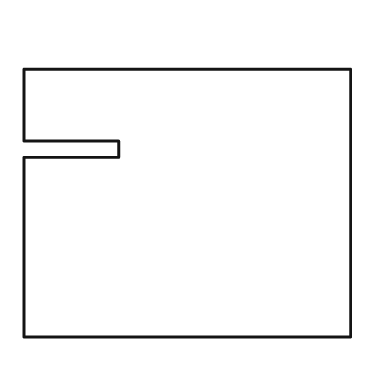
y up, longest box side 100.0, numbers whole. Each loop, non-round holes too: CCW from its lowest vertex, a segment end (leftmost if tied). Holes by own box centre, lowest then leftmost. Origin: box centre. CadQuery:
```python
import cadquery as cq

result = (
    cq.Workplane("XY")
    .moveTo(-50.0, -41.0)
    .lineTo(50.0, -41.0)
    .lineTo(50.0, 41.0)
    .lineTo(-50.0, 41.0)
    .lineTo(-50.0, 19.0)
    .lineTo(-21.0, 19.0)
    .lineTo(-21.0, 14.0)
    .lineTo(-50.0, 14.0)
    .close()
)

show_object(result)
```